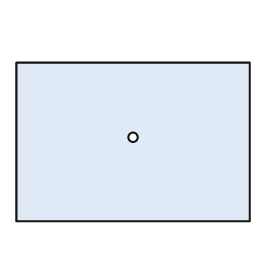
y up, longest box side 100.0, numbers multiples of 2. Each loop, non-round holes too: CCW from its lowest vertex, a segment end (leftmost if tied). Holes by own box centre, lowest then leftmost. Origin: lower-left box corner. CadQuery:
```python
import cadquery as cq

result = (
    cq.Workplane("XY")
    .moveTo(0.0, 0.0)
    .lineTo(100.0, 0.0)
    .lineTo(100.0, 68.0)
    .lineTo(0.0, 68.0)
    .close()
    .moveTo(50.0, 36.0)
    .circle(2.0)
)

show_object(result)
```